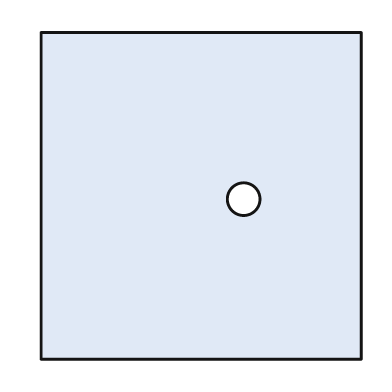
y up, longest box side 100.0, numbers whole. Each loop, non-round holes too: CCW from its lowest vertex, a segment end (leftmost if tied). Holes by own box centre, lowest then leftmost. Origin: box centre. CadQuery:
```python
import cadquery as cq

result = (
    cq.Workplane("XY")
    .moveTo(-49.0, -50.0)
    .lineTo(49.0, -50.0)
    .lineTo(49.0, 50.0)
    .lineTo(-49.0, 50.0)
    .close()
    .moveTo(13.0, -1.0)
    .circle(5.0)
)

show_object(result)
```